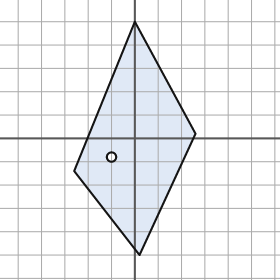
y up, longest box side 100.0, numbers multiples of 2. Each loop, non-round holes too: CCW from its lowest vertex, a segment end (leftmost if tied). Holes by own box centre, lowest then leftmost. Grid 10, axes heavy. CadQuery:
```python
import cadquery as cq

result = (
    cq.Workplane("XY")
    .moveTo(2.0, -50.0)
    .lineTo(26.0, 2.0)
    .lineTo(0.0, 50.0)
    .lineTo(-26.0, -14.0)
    .close()
    .moveTo(-10.0, -8.0)
    .circle(2.0)
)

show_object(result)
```